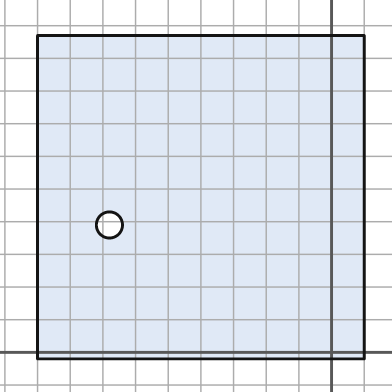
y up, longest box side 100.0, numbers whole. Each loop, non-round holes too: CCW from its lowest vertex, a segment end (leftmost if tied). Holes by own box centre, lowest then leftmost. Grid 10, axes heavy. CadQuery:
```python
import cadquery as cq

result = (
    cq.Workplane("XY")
    .moveTo(-90.0, -2.0)
    .lineTo(10.0, -2.0)
    .lineTo(10.0, 97.0)
    .lineTo(-90.0, 97.0)
    .close()
    .moveTo(-68.0, 39.0)
    .circle(4.0)
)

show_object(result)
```